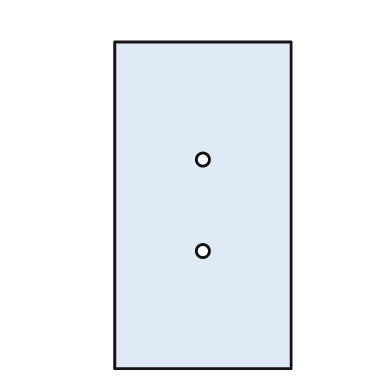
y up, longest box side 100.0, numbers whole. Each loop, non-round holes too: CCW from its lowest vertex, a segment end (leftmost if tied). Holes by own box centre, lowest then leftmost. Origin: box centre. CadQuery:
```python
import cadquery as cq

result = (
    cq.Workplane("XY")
    .moveTo(-27.0, -50.0)
    .lineTo(27.0, -50.0)
    .lineTo(27.0, 50.0)
    .lineTo(-27.0, 50.0)
    .close()
    .moveTo(0.0, -14.0)
    .circle(2.0)
    .moveTo(0.0, 14.0)
    .circle(2.0)
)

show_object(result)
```